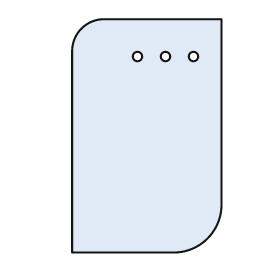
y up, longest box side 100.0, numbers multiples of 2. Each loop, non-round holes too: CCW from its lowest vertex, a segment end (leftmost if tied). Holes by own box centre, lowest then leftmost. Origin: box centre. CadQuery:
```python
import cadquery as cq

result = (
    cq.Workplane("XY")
    .moveTo(-32.0, -50.0)
    .lineTo(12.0, -50.0)
    .threePointArc((26.0, -44.0), (32.0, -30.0))
    .lineTo(32.0, 50.0)
    .lineTo(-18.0, 50.0)
    .threePointArc((-28.0, 46.0), (-32.0, 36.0))
    .close()
    .moveTo(-4.0, 34.0)
    .circle(2.0)
    .moveTo(8.0, 34.0)
    .circle(2.0)
    .moveTo(20.0, 34.0)
    .circle(2.0)
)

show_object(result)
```